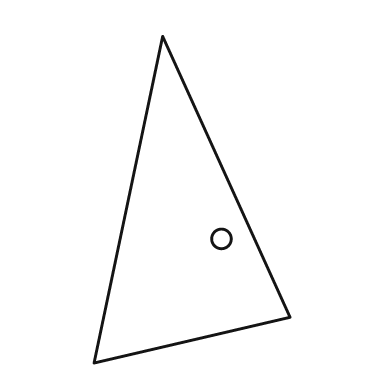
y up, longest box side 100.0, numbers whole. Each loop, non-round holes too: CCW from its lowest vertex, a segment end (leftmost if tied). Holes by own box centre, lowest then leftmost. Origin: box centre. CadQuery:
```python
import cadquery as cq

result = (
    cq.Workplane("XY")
    .moveTo(-30.0, -50.0)
    .lineTo(30.0, -36.0)
    .lineTo(-9.0, 50.0)
    .close()
    .moveTo(9.0, -12.0)
    .circle(3.0)
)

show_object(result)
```